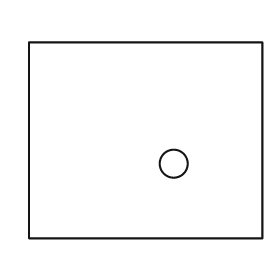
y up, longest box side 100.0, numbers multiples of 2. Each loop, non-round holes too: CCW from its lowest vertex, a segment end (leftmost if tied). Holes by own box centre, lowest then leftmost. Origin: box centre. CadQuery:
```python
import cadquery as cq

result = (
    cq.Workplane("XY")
    .moveTo(-50.0, -42.0)
    .lineTo(50.0, -42.0)
    .lineTo(50.0, 42.0)
    .lineTo(-50.0, 42.0)
    .close()
    .moveTo(12.0, -10.0)
    .circle(6.0)
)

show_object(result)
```